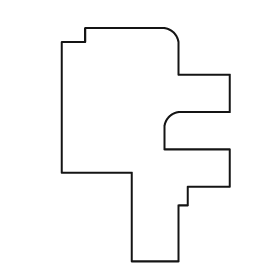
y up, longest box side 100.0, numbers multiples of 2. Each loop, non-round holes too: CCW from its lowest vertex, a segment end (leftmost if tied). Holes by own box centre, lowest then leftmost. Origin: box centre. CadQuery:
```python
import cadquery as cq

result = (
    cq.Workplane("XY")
    .moveTo(-6.0, -50.0)
    .lineTo(14.0, -50.0)
    .lineTo(14.0, -26.0)
    .lineTo(18.0, -26.0)
    .lineTo(18.0, -18.0)
    .lineTo(36.0, -18.0)
    .lineTo(36.0, -2.0)
    .lineTo(8.0, -2.0)
    .lineTo(8.0, 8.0)
    .threePointArc((10.0, 12.0), (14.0, 14.0))
    .lineTo(36.0, 14.0)
    .lineTo(36.0, 30.0)
    .lineTo(14.0, 30.0)
    .lineTo(14.0, 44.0)
    .threePointArc((12.0, 48.0), (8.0, 50.0))
    .lineTo(-26.0, 50.0)
    .lineTo(-26.0, 44.0)
    .lineTo(-36.0, 44.0)
    .lineTo(-36.0, -12.0)
    .lineTo(-6.0, -12.0)
    .close()
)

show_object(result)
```